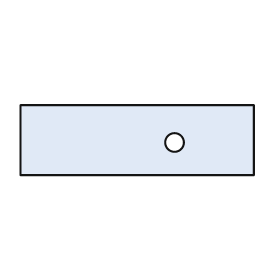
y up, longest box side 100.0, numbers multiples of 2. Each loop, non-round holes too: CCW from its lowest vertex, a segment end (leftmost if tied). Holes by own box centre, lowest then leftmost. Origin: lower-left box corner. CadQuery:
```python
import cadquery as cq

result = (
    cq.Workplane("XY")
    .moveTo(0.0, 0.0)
    .lineTo(100.0, 0.0)
    .lineTo(100.0, 30.0)
    .lineTo(0.0, 30.0)
    .close()
    .moveTo(66.0, 14.0)
    .circle(4.0)
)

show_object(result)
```